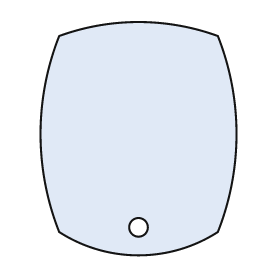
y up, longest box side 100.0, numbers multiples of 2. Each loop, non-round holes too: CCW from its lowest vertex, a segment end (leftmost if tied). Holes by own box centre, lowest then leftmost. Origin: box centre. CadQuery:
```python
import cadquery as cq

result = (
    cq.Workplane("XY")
    .moveTo(-34.0, -40.0)
    .threePointArc((0.0, -50.0), (34.0, -40.0))
    .threePointArc((42.0, 2.0), (34.0, 44.0))
    .threePointArc((0.0, 50.0), (-34.0, 44.0))
    .threePointArc((-42.0, 2.0), (-34.0, -40.0))
    .close()
    .moveTo(0.0, -38.0)
    .circle(4.0)
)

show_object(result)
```